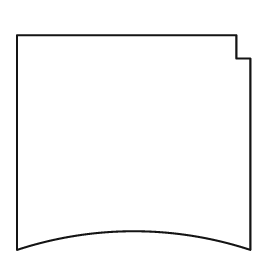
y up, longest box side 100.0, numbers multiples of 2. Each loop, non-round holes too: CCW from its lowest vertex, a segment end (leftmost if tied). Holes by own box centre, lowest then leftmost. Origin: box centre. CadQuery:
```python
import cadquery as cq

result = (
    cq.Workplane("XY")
    .moveTo(-50.0, -46.0)
    .threePointArc((0.0, -38.0), (50.0, -46.0))
    .lineTo(50.0, 36.0)
    .lineTo(44.0, 36.0)
    .lineTo(44.0, 46.0)
    .lineTo(-50.0, 46.0)
    .close()
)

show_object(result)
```